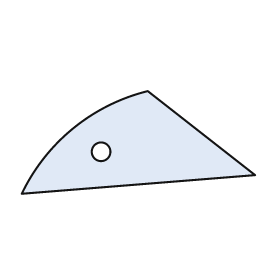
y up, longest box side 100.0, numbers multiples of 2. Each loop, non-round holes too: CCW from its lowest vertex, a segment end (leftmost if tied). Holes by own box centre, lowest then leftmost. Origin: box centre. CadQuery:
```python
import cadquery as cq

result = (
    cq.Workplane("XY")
    .moveTo(-50.0, -22.0)
    .lineTo(50.0, -14.0)
    .lineTo(4.0, 22.0)
    .threePointArc((-28.0, 6.0), (-50.0, -22.0))
    .close()
    .moveTo(-16.0, -4.0)
    .circle(4.0)
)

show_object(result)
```